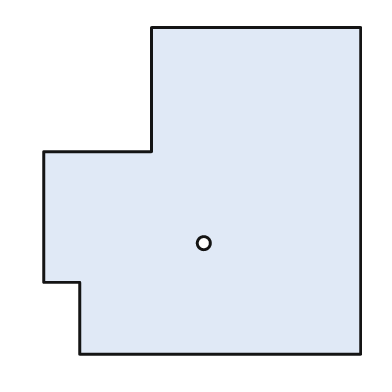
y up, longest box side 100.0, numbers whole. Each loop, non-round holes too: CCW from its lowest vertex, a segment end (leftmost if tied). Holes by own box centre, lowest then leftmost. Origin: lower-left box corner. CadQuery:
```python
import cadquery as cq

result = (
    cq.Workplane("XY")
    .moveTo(11.0, 0.0)
    .lineTo(97.0, 0.0)
    .lineTo(97.0, 100.0)
    .lineTo(33.0, 100.0)
    .lineTo(33.0, 62.0)
    .lineTo(0.0, 62.0)
    .lineTo(0.0, 22.0)
    .lineTo(11.0, 22.0)
    .close()
    .moveTo(49.0, 34.0)
    .circle(2.0)
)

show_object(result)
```